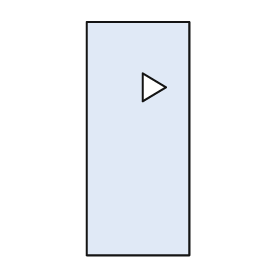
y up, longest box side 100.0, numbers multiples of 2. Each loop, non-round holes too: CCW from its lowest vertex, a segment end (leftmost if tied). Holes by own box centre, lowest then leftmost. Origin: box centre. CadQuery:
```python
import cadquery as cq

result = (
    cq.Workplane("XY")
    .moveTo(-22.0, -50.0)
    .lineTo(22.0, -50.0)
    .lineTo(22.0, 50.0)
    .lineTo(-22.0, 50.0)
    .close()
    .moveTo(2.0, 16.0)
    .lineTo(12.0, 22.0)
    .lineTo(2.0, 28.0)
    .close()
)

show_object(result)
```